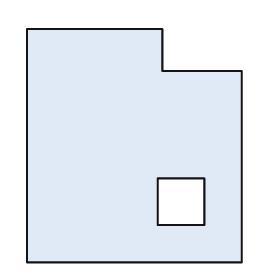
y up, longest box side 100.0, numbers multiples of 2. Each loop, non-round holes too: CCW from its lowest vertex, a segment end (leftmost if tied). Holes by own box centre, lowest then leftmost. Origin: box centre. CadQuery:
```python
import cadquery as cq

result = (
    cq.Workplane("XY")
    .moveTo(-46.0, -50.0)
    .lineTo(46.0, -50.0)
    .lineTo(46.0, 32.0)
    .lineTo(12.0, 32.0)
    .lineTo(12.0, 50.0)
    .lineTo(-46.0, 50.0)
    .close()
    .moveTo(10.0, -34.0)
    .lineTo(30.0, -34.0)
    .lineTo(30.0, -14.0)
    .lineTo(10.0, -14.0)
    .close()
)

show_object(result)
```